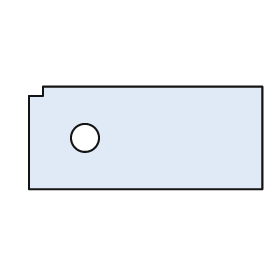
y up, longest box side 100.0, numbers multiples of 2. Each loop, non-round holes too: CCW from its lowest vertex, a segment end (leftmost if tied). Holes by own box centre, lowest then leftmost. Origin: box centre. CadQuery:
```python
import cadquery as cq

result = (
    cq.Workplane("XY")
    .moveTo(-50.0, -22.0)
    .lineTo(50.0, -22.0)
    .lineTo(50.0, 22.0)
    .lineTo(-44.0, 22.0)
    .lineTo(-44.0, 18.0)
    .lineTo(-50.0, 18.0)
    .close()
    .moveTo(-26.0, 0.0)
    .circle(6.0)
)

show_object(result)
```